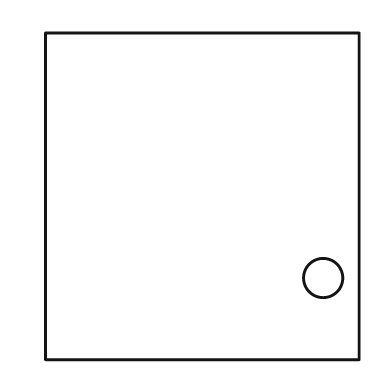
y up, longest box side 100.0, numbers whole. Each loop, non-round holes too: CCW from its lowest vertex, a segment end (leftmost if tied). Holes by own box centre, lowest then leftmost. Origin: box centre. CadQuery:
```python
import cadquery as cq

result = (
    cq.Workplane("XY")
    .moveTo(-48.0, -50.0)
    .lineTo(48.0, -50.0)
    .lineTo(48.0, 50.0)
    .lineTo(-48.0, 50.0)
    .close()
    .moveTo(37.0, -25.0)
    .circle(6.0)
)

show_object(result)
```